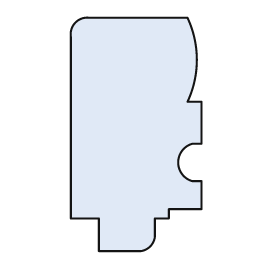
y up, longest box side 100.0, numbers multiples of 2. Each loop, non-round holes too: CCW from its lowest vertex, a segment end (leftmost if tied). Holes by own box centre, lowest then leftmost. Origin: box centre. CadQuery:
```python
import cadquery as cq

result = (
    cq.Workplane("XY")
    .moveTo(-16.0, -50.0)
    .lineTo(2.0, -50.0)
    .threePointArc((6.0, -48.0), (8.0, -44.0))
    .lineTo(8.0, -36.0)
    .lineTo(14.0, -36.0)
    .lineTo(14.0, -32.0)
    .lineTo(28.0, -32.0)
    .lineTo(28.0, -20.0)
    .lineTo(24.0, -20.0)
    .threePointArc((18.0, -12.0), (24.0, -4.0))
    .lineTo(28.0, -4.0)
    .lineTo(28.0, 14.0)
    .lineTo(22.0, 14.0)
    .threePointArc((26.0, 32.0), (22.0, 50.0))
    .lineTo(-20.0, 50.0)
    .threePointArc((-26.0, 48.0), (-28.0, 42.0))
    .lineTo(-28.0, -36.0)
    .lineTo(-16.0, -36.0)
    .close()
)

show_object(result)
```